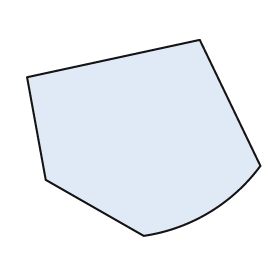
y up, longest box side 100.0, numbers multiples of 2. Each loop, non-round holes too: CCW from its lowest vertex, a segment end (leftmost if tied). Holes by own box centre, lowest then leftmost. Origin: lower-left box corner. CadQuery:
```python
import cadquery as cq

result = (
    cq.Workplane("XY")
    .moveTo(50.0, 0.0)
    .threePointArc((78.0, 10.0), (100.0, 30.0))
    .lineTo(74.0, 84.0)
    .lineTo(0.0, 68.0)
    .lineTo(8.0, 24.0)
    .close()
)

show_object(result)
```